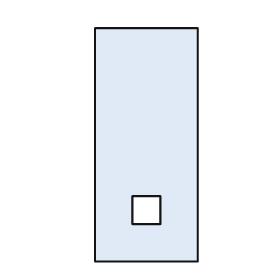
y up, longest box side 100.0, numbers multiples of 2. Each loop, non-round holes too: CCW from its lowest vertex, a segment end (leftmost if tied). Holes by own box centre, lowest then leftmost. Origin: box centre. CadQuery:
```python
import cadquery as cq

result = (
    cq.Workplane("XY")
    .moveTo(-22.0, -50.0)
    .lineTo(22.0, -50.0)
    .lineTo(22.0, 50.0)
    .lineTo(-22.0, 50.0)
    .close()
    .moveTo(-6.0, -34.0)
    .lineTo(6.0, -34.0)
    .lineTo(6.0, -22.0)
    .lineTo(-6.0, -22.0)
    .close()
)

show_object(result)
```